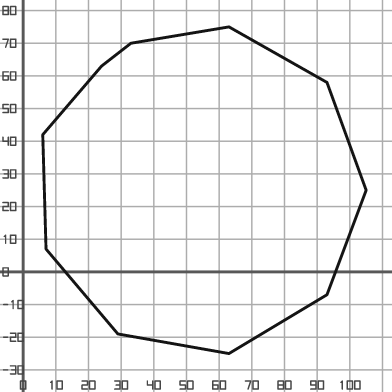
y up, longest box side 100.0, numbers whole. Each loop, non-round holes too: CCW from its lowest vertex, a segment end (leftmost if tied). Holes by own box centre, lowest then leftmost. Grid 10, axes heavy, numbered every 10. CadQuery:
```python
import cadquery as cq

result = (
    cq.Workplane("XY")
    .moveTo(63.0, -25.0)
    .lineTo(93.0, -7.0)
    .lineTo(105.0, 25.0)
    .lineTo(93.0, 58.0)
    .lineTo(63.0, 75.0)
    .lineTo(33.0, 70.0)
    .lineTo(24.0, 63.0)
    .lineTo(6.0, 42.0)
    .lineTo(7.0, 7.0)
    .lineTo(29.0, -19.0)
    .close()
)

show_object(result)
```